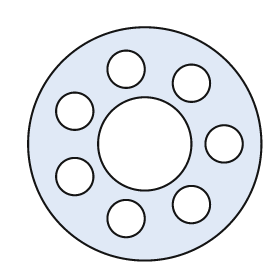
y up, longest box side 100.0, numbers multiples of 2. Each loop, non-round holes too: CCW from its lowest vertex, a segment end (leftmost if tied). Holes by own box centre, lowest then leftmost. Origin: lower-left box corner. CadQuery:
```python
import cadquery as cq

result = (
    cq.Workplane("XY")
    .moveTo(50.0, 50.0)
    .circle(50.0)
    .moveTo(42.0, 18.0)
    .circle(8.0)
    .moveTo(70.0, 24.0)
    .circle(8.0)
    .moveTo(20.0, 36.0)
    .circle(8.0)
    .moveTo(50.0, 50.0)
    .circle(20.0)
    .moveTo(84.0, 50.0)
    .circle(8.0)
    .moveTo(20.0, 64.0)
    .circle(8.0)
    .moveTo(70.0, 76.0)
    .circle(8.0)
    .moveTo(42.0, 82.0)
    .circle(8.0)
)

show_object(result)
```